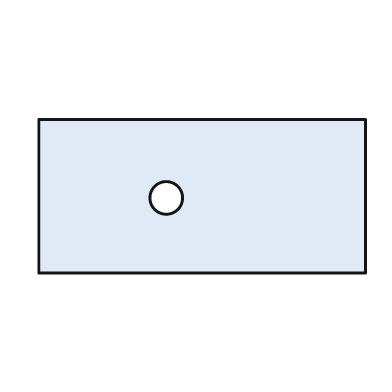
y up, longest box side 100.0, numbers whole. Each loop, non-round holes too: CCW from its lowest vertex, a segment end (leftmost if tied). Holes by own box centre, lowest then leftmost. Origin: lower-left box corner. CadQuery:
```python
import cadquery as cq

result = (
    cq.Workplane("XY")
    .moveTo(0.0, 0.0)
    .lineTo(100.0, 0.0)
    .lineTo(100.0, 47.0)
    .lineTo(0.0, 47.0)
    .close()
    .moveTo(39.0, 23.0)
    .circle(5.0)
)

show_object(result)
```